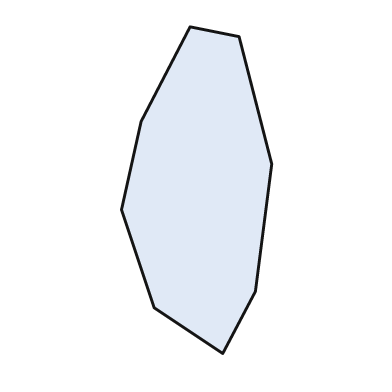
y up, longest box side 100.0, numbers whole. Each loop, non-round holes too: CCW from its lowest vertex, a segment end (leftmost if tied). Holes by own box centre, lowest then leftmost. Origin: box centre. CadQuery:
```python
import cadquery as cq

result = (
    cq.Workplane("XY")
    .moveTo(8.0, -50.0)
    .lineTo(18.0, -31.0)
    .lineTo(23.0, 8.0)
    .lineTo(13.0, 47.0)
    .lineTo(-2.0, 50.0)
    .lineTo(-17.0, 21.0)
    .lineTo(-23.0, -6.0)
    .lineTo(-13.0, -36.0)
    .close()
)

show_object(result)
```